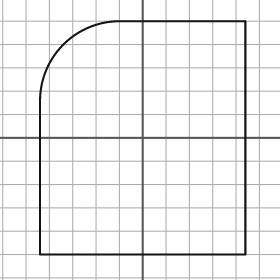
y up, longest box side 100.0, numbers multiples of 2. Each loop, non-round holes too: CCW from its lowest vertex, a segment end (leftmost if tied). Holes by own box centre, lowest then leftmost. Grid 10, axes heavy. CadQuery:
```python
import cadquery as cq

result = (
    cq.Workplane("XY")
    .moveTo(-44.0, -50.0)
    .lineTo(44.0, -50.0)
    .lineTo(44.0, 50.0)
    .lineTo(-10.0, 50.0)
    .threePointArc((-34.0, 40.0), (-44.0, 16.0))
    .close()
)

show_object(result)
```